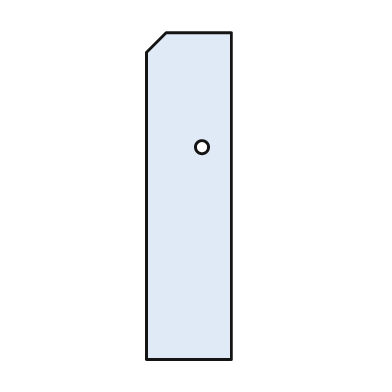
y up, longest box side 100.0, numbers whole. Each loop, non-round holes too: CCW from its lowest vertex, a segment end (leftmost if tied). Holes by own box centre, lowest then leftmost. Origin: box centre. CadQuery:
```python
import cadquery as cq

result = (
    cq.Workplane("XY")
    .moveTo(-13.0, -50.0)
    .lineTo(13.0, -50.0)
    .lineTo(13.0, 50.0)
    .lineTo(-7.0, 50.0)
    .lineTo(-13.0, 44.0)
    .close()
    .moveTo(4.0, 15.0)
    .circle(2.0)
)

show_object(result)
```